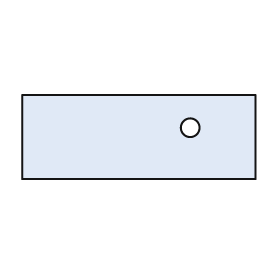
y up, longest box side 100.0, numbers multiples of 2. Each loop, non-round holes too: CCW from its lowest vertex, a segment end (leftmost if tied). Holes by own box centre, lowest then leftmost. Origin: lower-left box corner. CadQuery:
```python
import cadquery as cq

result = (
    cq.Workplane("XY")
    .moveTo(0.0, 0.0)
    .lineTo(100.0, 0.0)
    .lineTo(100.0, 36.0)
    .lineTo(0.0, 36.0)
    .close()
    .moveTo(72.0, 22.0)
    .circle(4.0)
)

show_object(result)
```